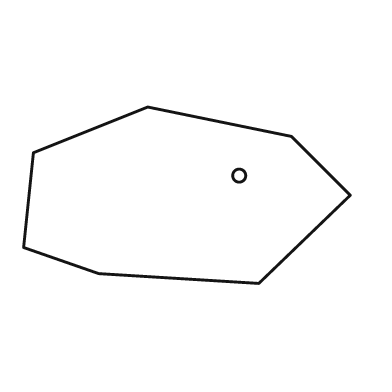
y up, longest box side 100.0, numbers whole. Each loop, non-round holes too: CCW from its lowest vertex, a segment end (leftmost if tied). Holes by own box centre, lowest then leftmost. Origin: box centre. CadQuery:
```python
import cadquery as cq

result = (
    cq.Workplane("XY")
    .moveTo(22.0, -27.0)
    .lineTo(50.0, 0.0)
    .lineTo(32.0, 18.0)
    .lineTo(-12.0, 27.0)
    .lineTo(-47.0, 13.0)
    .lineTo(-50.0, -16.0)
    .lineTo(-27.0, -24.0)
    .close()
    .moveTo(16.0, 6.0)
    .circle(2.0)
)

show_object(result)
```